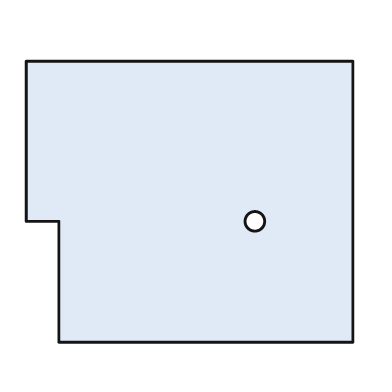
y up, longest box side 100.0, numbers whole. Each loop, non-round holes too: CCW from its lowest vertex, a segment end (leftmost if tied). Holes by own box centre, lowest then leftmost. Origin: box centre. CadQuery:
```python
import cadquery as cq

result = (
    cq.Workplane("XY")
    .moveTo(-40.0, -43.0)
    .lineTo(50.0, -43.0)
    .lineTo(50.0, 43.0)
    .lineTo(-50.0, 43.0)
    .lineTo(-50.0, -6.0)
    .lineTo(-40.0, -6.0)
    .close()
    .moveTo(20.0, -6.0)
    .circle(3.0)
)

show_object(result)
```